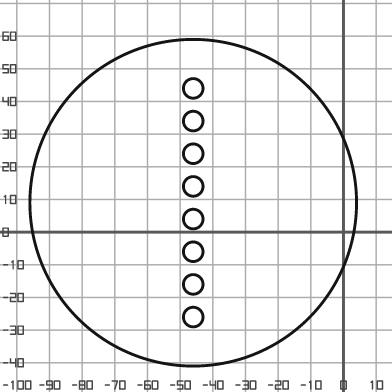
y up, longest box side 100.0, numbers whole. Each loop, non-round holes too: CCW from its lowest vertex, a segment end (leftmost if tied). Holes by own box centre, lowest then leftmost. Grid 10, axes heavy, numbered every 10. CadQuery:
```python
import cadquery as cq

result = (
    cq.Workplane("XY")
    .moveTo(-46.0, 9.0)
    .circle(50.0)
    .moveTo(-46.0, -26.0)
    .circle(3.0)
    .moveTo(-46.0, -16.0)
    .circle(3.0)
    .moveTo(-46.0, -6.0)
    .circle(3.0)
    .moveTo(-46.0, 4.0)
    .circle(3.0)
    .moveTo(-46.0, 14.0)
    .circle(3.0)
    .moveTo(-46.0, 24.0)
    .circle(3.0)
    .moveTo(-46.0, 34.0)
    .circle(3.0)
    .moveTo(-46.0, 44.0)
    .circle(3.0)
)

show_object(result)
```